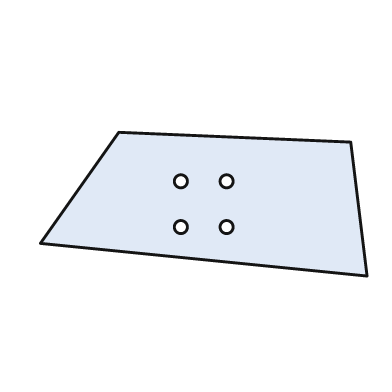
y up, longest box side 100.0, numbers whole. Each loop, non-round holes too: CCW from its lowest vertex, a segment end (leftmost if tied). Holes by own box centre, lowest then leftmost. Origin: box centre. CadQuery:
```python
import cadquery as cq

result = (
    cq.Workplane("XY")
    .moveTo(50.0, -22.0)
    .lineTo(45.0, 19.0)
    .lineTo(-26.0, 22.0)
    .lineTo(-50.0, -12.0)
    .close()
    .moveTo(-7.0, -7.0)
    .circle(2.0)
    .moveTo(7.0, -7.0)
    .circle(2.0)
    .moveTo(-7.0, 7.0)
    .circle(2.0)
    .moveTo(7.0, 7.0)
    .circle(2.0)
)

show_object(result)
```